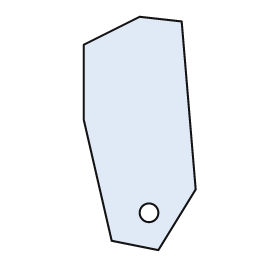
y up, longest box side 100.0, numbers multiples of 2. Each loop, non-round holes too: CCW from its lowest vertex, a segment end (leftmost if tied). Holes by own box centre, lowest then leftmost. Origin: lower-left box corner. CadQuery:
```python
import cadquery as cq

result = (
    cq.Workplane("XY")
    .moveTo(32.0, 0.0)
    .lineTo(48.0, 26.0)
    .lineTo(42.0, 98.0)
    .lineTo(24.0, 100.0)
    .lineTo(0.0, 88.0)
    .lineTo(0.0, 56.0)
    .lineTo(12.0, 4.0)
    .close()
    .moveTo(28.0, 16.0)
    .circle(4.0)
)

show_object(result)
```